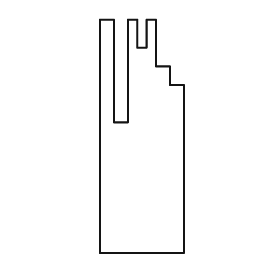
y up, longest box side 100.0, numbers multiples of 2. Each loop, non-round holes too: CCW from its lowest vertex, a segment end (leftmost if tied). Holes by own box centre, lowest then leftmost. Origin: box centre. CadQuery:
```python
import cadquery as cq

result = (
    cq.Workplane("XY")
    .moveTo(-18.0, -50.0)
    .lineTo(18.0, -50.0)
    .lineTo(18.0, 22.0)
    .lineTo(12.0, 22.0)
    .lineTo(12.0, 30.0)
    .lineTo(6.0, 30.0)
    .lineTo(6.0, 50.0)
    .lineTo(2.0, 50.0)
    .lineTo(2.0, 38.0)
    .lineTo(-2.0, 38.0)
    .lineTo(-2.0, 50.0)
    .lineTo(-6.0, 50.0)
    .lineTo(-6.0, 6.0)
    .lineTo(-12.0, 6.0)
    .lineTo(-12.0, 50.0)
    .lineTo(-18.0, 50.0)
    .close()
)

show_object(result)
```